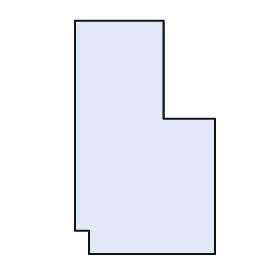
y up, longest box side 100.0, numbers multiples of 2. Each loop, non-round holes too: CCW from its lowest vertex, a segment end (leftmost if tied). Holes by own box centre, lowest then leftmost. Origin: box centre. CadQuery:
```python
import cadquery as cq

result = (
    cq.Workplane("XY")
    .moveTo(-24.0, -50.0)
    .lineTo(30.0, -50.0)
    .lineTo(30.0, 8.0)
    .lineTo(8.0, 8.0)
    .lineTo(8.0, 50.0)
    .lineTo(-30.0, 50.0)
    .lineTo(-30.0, -40.0)
    .lineTo(-24.0, -40.0)
    .close()
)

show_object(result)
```